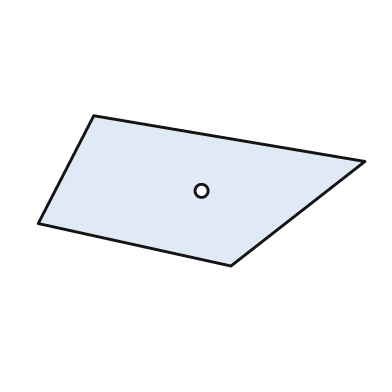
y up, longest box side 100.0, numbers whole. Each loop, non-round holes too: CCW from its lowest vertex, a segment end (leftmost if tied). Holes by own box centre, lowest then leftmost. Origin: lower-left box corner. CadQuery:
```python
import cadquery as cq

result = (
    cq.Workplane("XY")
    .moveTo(59.0, 0.0)
    .lineTo(100.0, 32.0)
    .lineTo(17.0, 46.0)
    .lineTo(0.0, 13.0)
    .close()
    .moveTo(50.0, 23.0)
    .circle(2.0)
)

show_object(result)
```